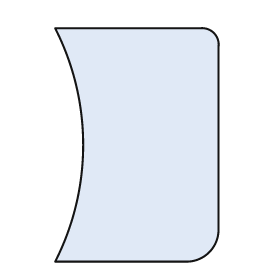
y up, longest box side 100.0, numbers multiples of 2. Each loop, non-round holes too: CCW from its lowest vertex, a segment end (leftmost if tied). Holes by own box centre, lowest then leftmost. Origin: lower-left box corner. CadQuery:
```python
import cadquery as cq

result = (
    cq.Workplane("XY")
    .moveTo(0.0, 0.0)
    .lineTo(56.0, 0.0)
    .threePointArc((66.0, 4.0), (70.0, 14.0))
    .lineTo(70.0, 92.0)
    .threePointArc((68.0, 98.0), (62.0, 100.0))
    .lineTo(0.0, 100.0)
    .threePointArc((12.0, 50.0), (0.0, 0.0))
    .close()
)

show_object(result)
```